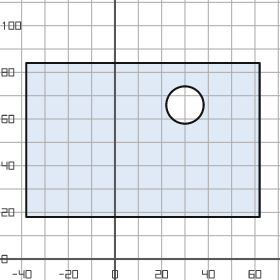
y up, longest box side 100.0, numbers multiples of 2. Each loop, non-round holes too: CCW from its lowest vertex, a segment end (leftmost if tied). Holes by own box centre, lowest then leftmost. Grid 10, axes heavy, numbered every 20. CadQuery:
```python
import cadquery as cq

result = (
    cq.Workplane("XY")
    .moveTo(-38.0, 18.0)
    .lineTo(62.0, 18.0)
    .lineTo(62.0, 84.0)
    .lineTo(-38.0, 84.0)
    .close()
    .moveTo(30.0, 66.0)
    .circle(8.0)
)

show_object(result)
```